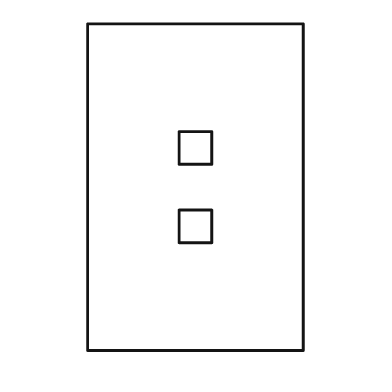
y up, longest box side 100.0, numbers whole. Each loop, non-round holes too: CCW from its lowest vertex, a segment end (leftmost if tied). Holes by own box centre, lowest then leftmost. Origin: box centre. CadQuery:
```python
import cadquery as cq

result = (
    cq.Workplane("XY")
    .moveTo(-33.0, -50.0)
    .lineTo(33.0, -50.0)
    .lineTo(33.0, 50.0)
    .lineTo(-33.0, 50.0)
    .close()
    .moveTo(-5.0, -17.0)
    .lineTo(5.0, -17.0)
    .lineTo(5.0, -7.0)
    .lineTo(-5.0, -7.0)
    .close()
    .moveTo(-5.0, 7.0)
    .lineTo(5.0, 7.0)
    .lineTo(5.0, 17.0)
    .lineTo(-5.0, 17.0)
    .close()
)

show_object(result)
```